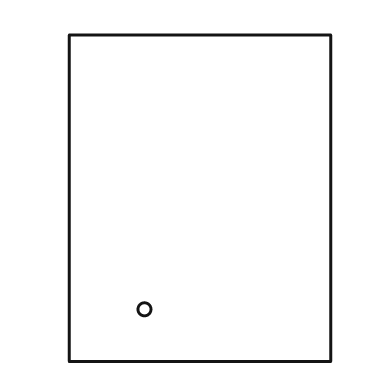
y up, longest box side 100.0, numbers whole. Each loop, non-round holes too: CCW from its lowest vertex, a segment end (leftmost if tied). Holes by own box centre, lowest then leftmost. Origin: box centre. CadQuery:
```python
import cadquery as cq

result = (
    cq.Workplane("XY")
    .moveTo(-40.0, -50.0)
    .lineTo(40.0, -50.0)
    .lineTo(40.0, 50.0)
    .lineTo(-40.0, 50.0)
    .close()
    .moveTo(-17.0, -34.0)
    .circle(2.0)
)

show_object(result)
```